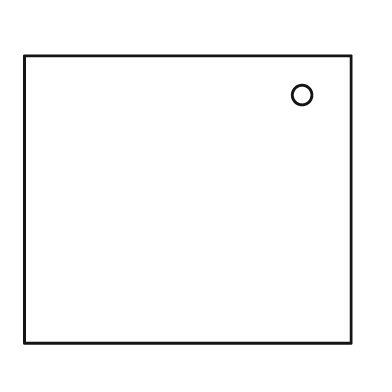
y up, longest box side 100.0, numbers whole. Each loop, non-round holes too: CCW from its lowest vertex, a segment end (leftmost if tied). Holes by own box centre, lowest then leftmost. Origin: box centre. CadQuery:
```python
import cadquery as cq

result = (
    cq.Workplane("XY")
    .moveTo(-50.0, -44.0)
    .lineTo(50.0, -44.0)
    .lineTo(50.0, 44.0)
    .lineTo(-50.0, 44.0)
    .close()
    .moveTo(35.0, 32.0)
    .circle(3.0)
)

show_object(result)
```